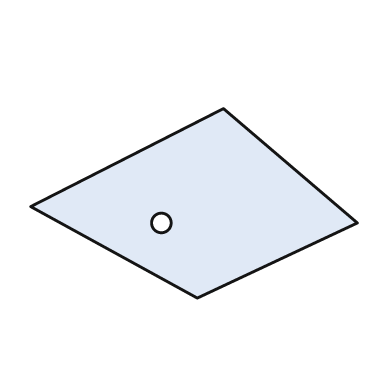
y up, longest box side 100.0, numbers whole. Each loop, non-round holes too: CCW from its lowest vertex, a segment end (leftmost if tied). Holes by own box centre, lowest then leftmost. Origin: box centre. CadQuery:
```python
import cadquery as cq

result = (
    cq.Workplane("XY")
    .moveTo(1.0, -29.0)
    .lineTo(50.0, -6.0)
    .lineTo(9.0, 29.0)
    .lineTo(-50.0, -1.0)
    .close()
    .moveTo(-10.0, -6.0)
    .circle(3.0)
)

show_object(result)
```